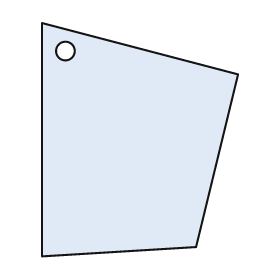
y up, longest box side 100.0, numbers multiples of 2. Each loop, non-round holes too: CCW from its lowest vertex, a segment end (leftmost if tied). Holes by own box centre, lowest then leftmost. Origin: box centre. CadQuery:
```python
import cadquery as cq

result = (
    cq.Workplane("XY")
    .moveTo(-42.0, -50.0)
    .lineTo(24.0, -46.0)
    .lineTo(42.0, 28.0)
    .lineTo(-42.0, 50.0)
    .close()
    .moveTo(-32.0, 38.0)
    .circle(4.0)
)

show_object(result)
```